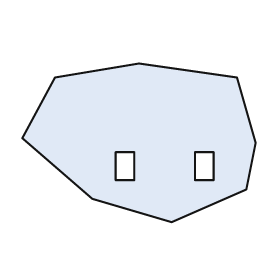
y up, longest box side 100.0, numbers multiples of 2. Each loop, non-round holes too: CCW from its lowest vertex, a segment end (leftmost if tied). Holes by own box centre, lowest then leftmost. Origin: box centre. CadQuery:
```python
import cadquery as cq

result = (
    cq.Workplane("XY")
    .moveTo(14.0, -34.0)
    .lineTo(46.0, -20.0)
    .lineTo(50.0, 0.0)
    .lineTo(42.0, 28.0)
    .lineTo(0.0, 34.0)
    .lineTo(-36.0, 28.0)
    .lineTo(-50.0, 2.0)
    .lineTo(-20.0, -24.0)
    .close()
    .moveTo(-10.0, -16.0)
    .lineTo(-2.0, -16.0)
    .lineTo(-2.0, -4.0)
    .lineTo(-10.0, -4.0)
    .close()
    .moveTo(24.0, -16.0)
    .lineTo(32.0, -16.0)
    .lineTo(32.0, -4.0)
    .lineTo(24.0, -4.0)
    .close()
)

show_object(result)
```